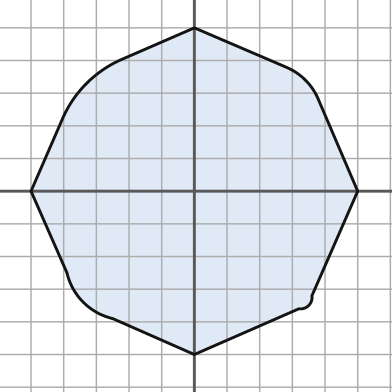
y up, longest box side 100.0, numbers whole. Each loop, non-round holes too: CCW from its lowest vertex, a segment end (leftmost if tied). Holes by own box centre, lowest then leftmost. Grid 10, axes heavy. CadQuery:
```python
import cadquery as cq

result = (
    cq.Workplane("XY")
    .moveTo(0.0, -50.0)
    .lineTo(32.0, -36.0)
    .threePointArc((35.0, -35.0), (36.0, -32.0))
    .lineTo(50.0, 0.0)
    .lineTo(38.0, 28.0)
    .threePointArc((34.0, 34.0), (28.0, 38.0))
    .lineTo(0.0, 50.0)
    .lineTo(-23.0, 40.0)
    .threePointArc((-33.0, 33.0), (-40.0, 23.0))
    .lineTo(-50.0, 0.0)
    .lineTo(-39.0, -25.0)
    .threePointArc((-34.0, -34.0), (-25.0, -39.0))
    .close()
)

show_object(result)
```